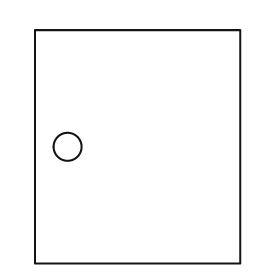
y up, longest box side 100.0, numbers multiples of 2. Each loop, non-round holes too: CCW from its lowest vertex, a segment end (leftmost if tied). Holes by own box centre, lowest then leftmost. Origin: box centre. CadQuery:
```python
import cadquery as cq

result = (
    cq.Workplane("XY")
    .moveTo(-44.0, -50.0)
    .lineTo(44.0, -50.0)
    .lineTo(44.0, 50.0)
    .lineTo(-44.0, 50.0)
    .close()
    .moveTo(-30.0, 0.0)
    .circle(6.0)
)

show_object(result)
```